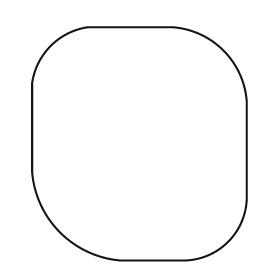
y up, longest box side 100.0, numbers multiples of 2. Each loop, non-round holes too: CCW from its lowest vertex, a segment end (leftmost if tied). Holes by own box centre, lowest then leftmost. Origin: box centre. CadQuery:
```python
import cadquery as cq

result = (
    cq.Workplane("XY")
    .moveTo(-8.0, -50.0)
    .lineTo(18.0, -50.0)
    .threePointArc((38.0, -42.0), (46.0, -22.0))
    .lineTo(46.0, 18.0)
    .threePointArc((36.0, 40.0), (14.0, 50.0))
    .lineTo(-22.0, 50.0)
    .threePointArc((-38.0, 42.0), (-46.0, 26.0))
    .lineTo(-46.0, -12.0)
    .threePointArc((-34.0, -38.0), (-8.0, -50.0))
    .close()
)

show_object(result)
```